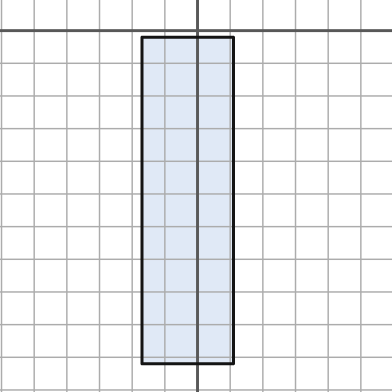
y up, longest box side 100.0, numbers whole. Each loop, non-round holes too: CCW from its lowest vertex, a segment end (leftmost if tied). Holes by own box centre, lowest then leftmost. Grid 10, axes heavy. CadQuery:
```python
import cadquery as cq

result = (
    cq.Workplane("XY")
    .moveTo(-17.0, -102.0)
    .lineTo(11.0, -102.0)
    .lineTo(11.0, -2.0)
    .lineTo(-17.0, -2.0)
    .close()
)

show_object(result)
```